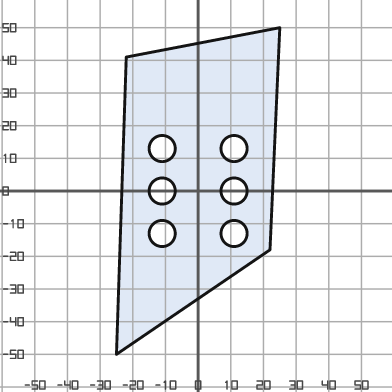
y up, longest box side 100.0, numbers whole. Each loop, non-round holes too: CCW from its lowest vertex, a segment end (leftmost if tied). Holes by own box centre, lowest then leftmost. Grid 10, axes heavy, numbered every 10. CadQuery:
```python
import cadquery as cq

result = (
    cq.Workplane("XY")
    .moveTo(-25.0, -50.0)
    .lineTo(22.0, -18.0)
    .lineTo(25.0, 50.0)
    .lineTo(-22.0, 41.0)
    .close()
    .moveTo(-11.0, -13.0)
    .circle(4.0)
    .moveTo(11.0, -13.0)
    .circle(4.0)
    .moveTo(-11.0, 0.0)
    .circle(4.0)
    .moveTo(11.0, 0.0)
    .circle(4.0)
    .moveTo(-11.0, 13.0)
    .circle(4.0)
    .moveTo(11.0, 13.0)
    .circle(4.0)
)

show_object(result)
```